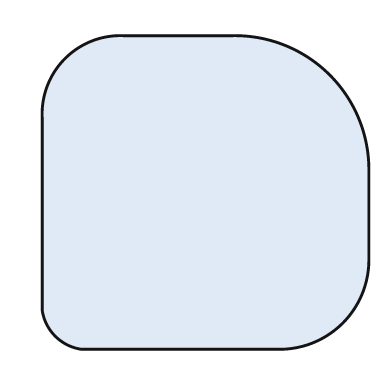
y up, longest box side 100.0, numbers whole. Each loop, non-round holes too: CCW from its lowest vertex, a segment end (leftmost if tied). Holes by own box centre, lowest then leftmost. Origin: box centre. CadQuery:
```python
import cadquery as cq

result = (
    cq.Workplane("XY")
    .moveTo(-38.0, -48.0)
    .lineTo(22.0, -48.0)
    .threePointArc((42.0, -40.0), (50.0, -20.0))
    .lineTo(50.0, 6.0)
    .threePointArc((38.0, 36.0), (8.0, 48.0))
    .lineTo(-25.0, 48.0)
    .threePointArc((-43.0, 41.0), (-50.0, 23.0))
    .lineTo(-50.0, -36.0)
    .threePointArc((-46.0, -44.0), (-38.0, -48.0))
    .close()
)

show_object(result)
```